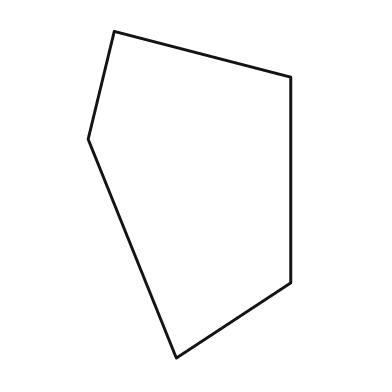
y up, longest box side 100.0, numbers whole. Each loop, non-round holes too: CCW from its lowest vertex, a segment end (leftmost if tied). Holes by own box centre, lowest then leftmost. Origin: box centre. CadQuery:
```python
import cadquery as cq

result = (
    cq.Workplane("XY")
    .moveTo(-4.0, -50.0)
    .lineTo(31.0, -27.0)
    .lineTo(31.0, 36.0)
    .lineTo(-23.0, 50.0)
    .lineTo(-31.0, 17.0)
    .close()
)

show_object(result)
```